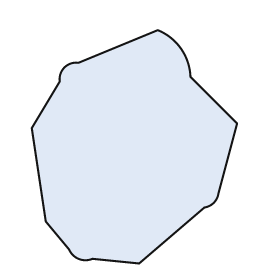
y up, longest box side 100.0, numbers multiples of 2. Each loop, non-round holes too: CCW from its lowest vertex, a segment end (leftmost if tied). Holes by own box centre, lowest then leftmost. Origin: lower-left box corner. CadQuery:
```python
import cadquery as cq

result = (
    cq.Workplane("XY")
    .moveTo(46.0, 0.0)
    .lineTo(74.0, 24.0)
    .threePointArc((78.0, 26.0), (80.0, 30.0))
    .lineTo(88.0, 60.0)
    .lineTo(68.0, 80.0)
    .threePointArc((64.0, 92.0), (54.0, 100.0))
    .lineTo(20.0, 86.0)
    .threePointArc((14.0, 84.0), (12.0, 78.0))
    .lineTo(0.0, 58.0)
    .lineTo(6.0, 18.0)
    .lineTo(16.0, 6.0)
    .threePointArc((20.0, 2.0), (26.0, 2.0))
    .close()
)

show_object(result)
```